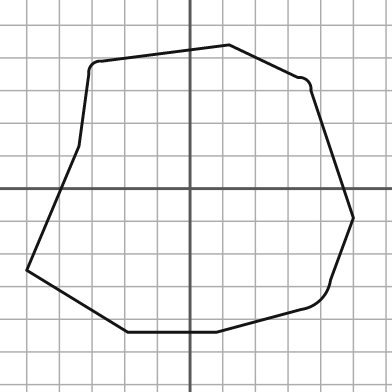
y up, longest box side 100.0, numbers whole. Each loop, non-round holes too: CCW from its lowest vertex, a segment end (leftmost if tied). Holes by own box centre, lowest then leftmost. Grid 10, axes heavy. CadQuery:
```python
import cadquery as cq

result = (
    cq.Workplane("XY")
    .moveTo(-19.0, -44.0)
    .lineTo(8.0, -44.0)
    .lineTo(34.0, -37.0)
    .threePointArc((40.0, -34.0), (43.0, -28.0))
    .lineTo(50.0, -9.0)
    .lineTo(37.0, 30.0)
    .threePointArc((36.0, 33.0), (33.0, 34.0))
    .lineTo(12.0, 44.0)
    .lineTo(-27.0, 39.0)
    .threePointArc((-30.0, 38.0), (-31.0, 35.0))
    .lineTo(-34.0, 13.0)
    .lineTo(-50.0, -25.0)
    .close()
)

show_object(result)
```